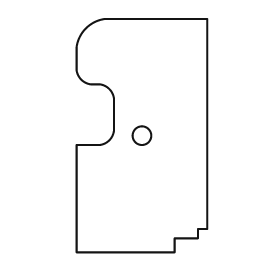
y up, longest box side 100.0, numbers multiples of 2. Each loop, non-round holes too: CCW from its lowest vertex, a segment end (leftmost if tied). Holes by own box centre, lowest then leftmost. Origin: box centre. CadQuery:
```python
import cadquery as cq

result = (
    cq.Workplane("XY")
    .moveTo(-28.0, -50.0)
    .lineTo(14.0, -50.0)
    .lineTo(14.0, -44.0)
    .lineTo(24.0, -44.0)
    .lineTo(24.0, -40.0)
    .lineTo(28.0, -40.0)
    .lineTo(28.0, 50.0)
    .lineTo(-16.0, 50.0)
    .threePointArc((-24.0, 46.0), (-28.0, 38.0))
    .lineTo(-28.0, 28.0)
    .threePointArc((-26.0, 24.0), (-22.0, 22.0))
    .lineTo(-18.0, 22.0)
    .threePointArc((-14.0, 20.0), (-12.0, 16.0))
    .lineTo(-12.0, 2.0)
    .threePointArc((-14.0, -2.0), (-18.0, -4.0))
    .lineTo(-28.0, -4.0)
    .close()
    .moveTo(0.0, 0.0)
    .circle(4.0)
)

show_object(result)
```